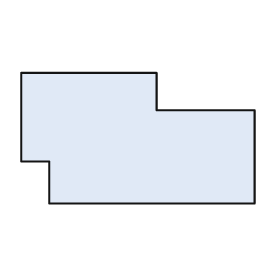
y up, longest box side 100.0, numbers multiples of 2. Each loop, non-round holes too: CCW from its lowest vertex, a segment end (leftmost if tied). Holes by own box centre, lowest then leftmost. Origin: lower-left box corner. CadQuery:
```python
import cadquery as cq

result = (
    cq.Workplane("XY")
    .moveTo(12.0, 0.0)
    .lineTo(100.0, 0.0)
    .lineTo(100.0, 40.0)
    .lineTo(58.0, 40.0)
    .lineTo(58.0, 56.0)
    .lineTo(0.0, 56.0)
    .lineTo(0.0, 18.0)
    .lineTo(12.0, 18.0)
    .close()
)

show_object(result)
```